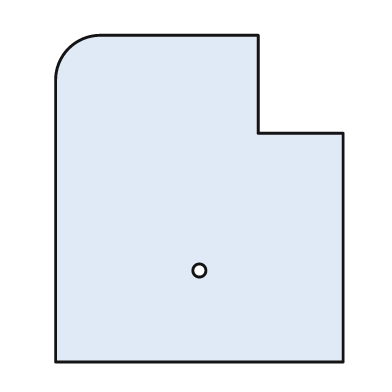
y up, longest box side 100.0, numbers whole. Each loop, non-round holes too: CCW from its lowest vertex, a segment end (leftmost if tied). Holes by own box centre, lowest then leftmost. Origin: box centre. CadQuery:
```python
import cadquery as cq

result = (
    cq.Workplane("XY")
    .moveTo(-44.0, -50.0)
    .lineTo(44.0, -50.0)
    .lineTo(44.0, 20.0)
    .lineTo(18.0, 20.0)
    .lineTo(18.0, 50.0)
    .lineTo(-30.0, 50.0)
    .threePointArc((-40.0, 46.0), (-44.0, 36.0))
    .close()
    .moveTo(0.0, -22.0)
    .circle(2.0)
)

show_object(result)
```